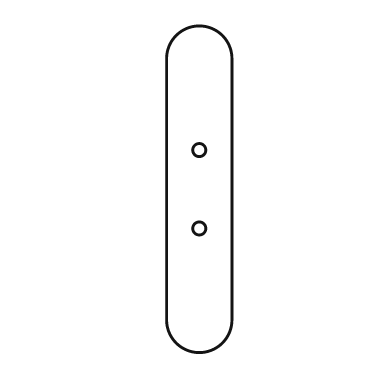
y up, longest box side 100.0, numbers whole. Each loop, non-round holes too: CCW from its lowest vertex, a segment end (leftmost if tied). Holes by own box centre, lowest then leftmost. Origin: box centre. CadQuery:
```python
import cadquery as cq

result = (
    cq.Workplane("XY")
    .moveTo(-10.0, -40.0)
    .threePointArc((0.0, -50.0), (10.0, -40.0))
    .lineTo(10.0, 40.0)
    .threePointArc((0.0, 50.0), (-10.0, 40.0))
    .close()
    .moveTo(0.0, -12.0)
    .circle(2.0)
    .moveTo(0.0, 12.0)
    .circle(2.0)
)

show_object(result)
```